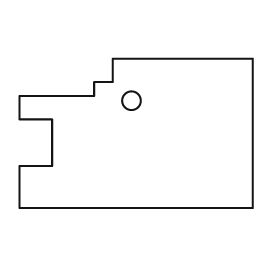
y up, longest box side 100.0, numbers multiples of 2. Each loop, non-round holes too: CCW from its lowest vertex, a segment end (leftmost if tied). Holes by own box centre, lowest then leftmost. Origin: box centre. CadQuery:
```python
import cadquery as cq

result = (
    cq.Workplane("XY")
    .moveTo(-50.0, -32.0)
    .lineTo(50.0, -32.0)
    .lineTo(50.0, 32.0)
    .lineTo(-10.0, 32.0)
    .lineTo(-10.0, 22.0)
    .lineTo(-18.0, 22.0)
    .lineTo(-18.0, 16.0)
    .lineTo(-50.0, 16.0)
    .lineTo(-50.0, 6.0)
    .lineTo(-36.0, 6.0)
    .lineTo(-36.0, -14.0)
    .lineTo(-50.0, -14.0)
    .close()
    .moveTo(-2.0, 14.0)
    .circle(4.0)
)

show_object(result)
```